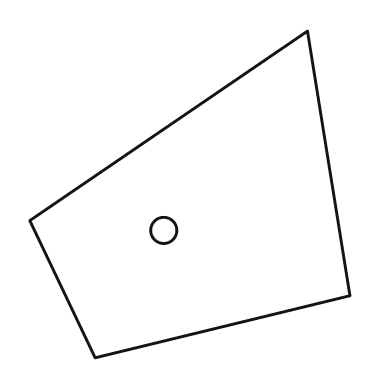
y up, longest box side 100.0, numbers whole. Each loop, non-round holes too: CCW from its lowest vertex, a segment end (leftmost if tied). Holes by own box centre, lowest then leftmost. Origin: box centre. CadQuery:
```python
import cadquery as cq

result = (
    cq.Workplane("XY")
    .moveTo(-29.0, -50.0)
    .lineTo(49.0, -31.0)
    .lineTo(36.0, 50.0)
    .lineTo(-49.0, -8.0)
    .close()
    .moveTo(-8.0, -11.0)
    .circle(4.0)
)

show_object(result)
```